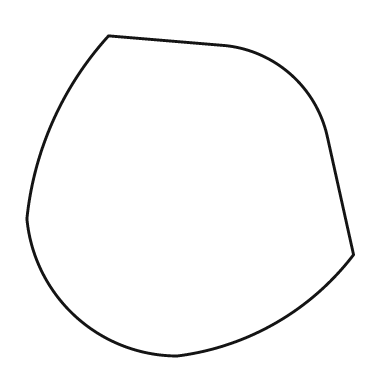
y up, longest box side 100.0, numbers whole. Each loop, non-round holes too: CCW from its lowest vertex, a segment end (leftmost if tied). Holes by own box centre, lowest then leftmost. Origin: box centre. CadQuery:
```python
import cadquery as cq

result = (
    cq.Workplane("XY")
    .moveTo(-4.0, -49.0)
    .threePointArc((26.0, -39.0), (50.0, -18.0))
    .lineTo(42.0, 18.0)
    .threePointArc((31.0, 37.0), (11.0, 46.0))
    .lineTo(-25.0, 49.0)
    .threePointArc((-42.0, 23.0), (-50.0, -7.0))
    .threePointArc((-35.0, -37.0), (-4.0, -49.0))
    .close()
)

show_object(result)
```